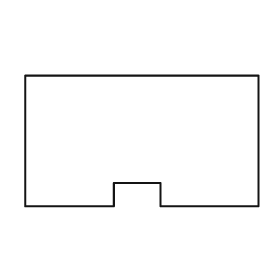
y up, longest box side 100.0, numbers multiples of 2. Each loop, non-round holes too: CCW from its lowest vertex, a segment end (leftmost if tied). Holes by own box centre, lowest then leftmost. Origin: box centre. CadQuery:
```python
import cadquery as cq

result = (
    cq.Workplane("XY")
    .moveTo(-50.0, -28.0)
    .lineTo(-12.0, -28.0)
    .lineTo(-12.0, -18.0)
    .lineTo(8.0, -18.0)
    .lineTo(8.0, -28.0)
    .lineTo(50.0, -28.0)
    .lineTo(50.0, 28.0)
    .lineTo(-50.0, 28.0)
    .close()
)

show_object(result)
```